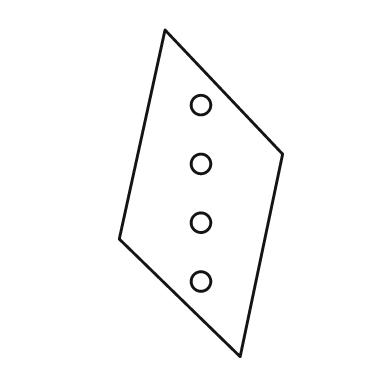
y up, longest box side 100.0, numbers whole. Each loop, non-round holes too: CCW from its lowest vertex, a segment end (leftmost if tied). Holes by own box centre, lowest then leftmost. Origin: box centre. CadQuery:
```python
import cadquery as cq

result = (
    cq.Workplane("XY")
    .moveTo(12.0, -50.0)
    .lineTo(25.0, 12.0)
    .lineTo(-11.0, 50.0)
    .lineTo(-25.0, -14.0)
    .close()
    .moveTo(0.0, -27.0)
    .circle(3.0)
    .moveTo(0.0, -9.0)
    .circle(3.0)
    .moveTo(0.0, 9.0)
    .circle(3.0)
    .moveTo(0.0, 27.0)
    .circle(3.0)
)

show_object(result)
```